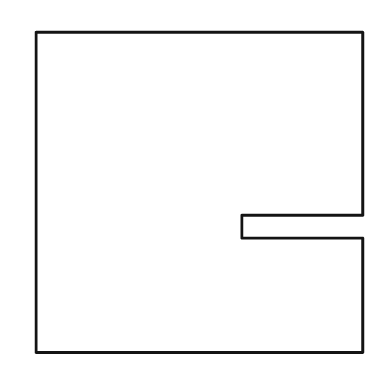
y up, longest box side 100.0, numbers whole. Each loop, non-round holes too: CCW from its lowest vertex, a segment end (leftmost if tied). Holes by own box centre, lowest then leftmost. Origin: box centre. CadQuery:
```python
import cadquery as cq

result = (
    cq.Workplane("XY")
    .moveTo(-50.0, -49.0)
    .lineTo(50.0, -49.0)
    .lineTo(50.0, -14.0)
    .lineTo(13.0, -14.0)
    .lineTo(13.0, -7.0)
    .lineTo(50.0, -7.0)
    .lineTo(50.0, 49.0)
    .lineTo(-50.0, 49.0)
    .close()
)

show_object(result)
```